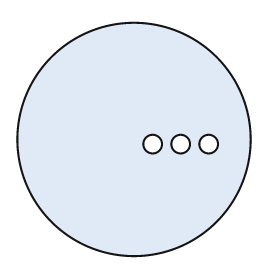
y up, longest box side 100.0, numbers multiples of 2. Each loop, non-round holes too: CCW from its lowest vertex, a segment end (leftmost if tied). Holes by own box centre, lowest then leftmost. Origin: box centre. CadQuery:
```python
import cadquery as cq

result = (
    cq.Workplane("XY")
    .moveTo(0.0, 0.0)
    .circle(50.0)
    .moveTo(8.0, -2.0)
    .circle(4.0)
    .moveTo(20.0, -2.0)
    .circle(4.0)
    .moveTo(32.0, -2.0)
    .circle(4.0)
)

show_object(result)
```